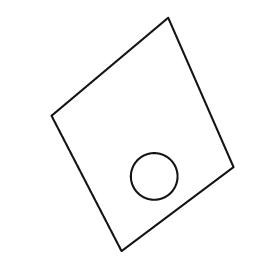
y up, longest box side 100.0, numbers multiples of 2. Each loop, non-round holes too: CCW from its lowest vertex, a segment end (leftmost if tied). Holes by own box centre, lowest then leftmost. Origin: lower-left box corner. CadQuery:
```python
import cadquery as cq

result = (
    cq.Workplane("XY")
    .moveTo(30.0, 0.0)
    .lineTo(78.0, 36.0)
    .lineTo(50.0, 100.0)
    .lineTo(0.0, 58.0)
    .close()
    .moveTo(44.0, 32.0)
    .circle(10.0)
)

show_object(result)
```